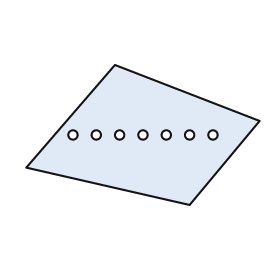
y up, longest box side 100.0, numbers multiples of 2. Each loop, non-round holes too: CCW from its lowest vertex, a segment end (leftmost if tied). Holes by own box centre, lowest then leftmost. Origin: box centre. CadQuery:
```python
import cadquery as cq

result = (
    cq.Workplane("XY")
    .moveTo(20.0, -30.0)
    .lineTo(50.0, 6.0)
    .lineTo(-12.0, 30.0)
    .lineTo(-50.0, -14.0)
    .close()
    .moveTo(-30.0, 0.0)
    .circle(2.0)
    .moveTo(-20.0, 0.0)
    .circle(2.0)
    .moveTo(-10.0, 0.0)
    .circle(2.0)
    .moveTo(0.0, 0.0)
    .circle(2.0)
    .moveTo(10.0, 0.0)
    .circle(2.0)
    .moveTo(20.0, 0.0)
    .circle(2.0)
    .moveTo(30.0, 0.0)
    .circle(2.0)
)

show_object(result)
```